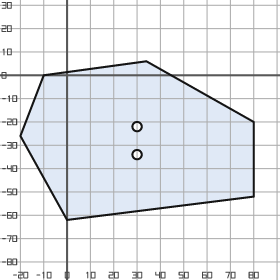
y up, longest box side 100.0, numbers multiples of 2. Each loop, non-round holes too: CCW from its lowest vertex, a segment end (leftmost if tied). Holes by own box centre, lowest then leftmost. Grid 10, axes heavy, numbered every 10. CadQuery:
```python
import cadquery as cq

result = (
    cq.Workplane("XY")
    .moveTo(0.0, -62.0)
    .lineTo(80.0, -52.0)
    .lineTo(80.0, -20.0)
    .lineTo(34.0, 6.0)
    .lineTo(-10.0, 0.0)
    .lineTo(-20.0, -26.0)
    .close()
    .moveTo(30.0, -34.0)
    .circle(2.0)
    .moveTo(30.0, -22.0)
    .circle(2.0)
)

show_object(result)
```